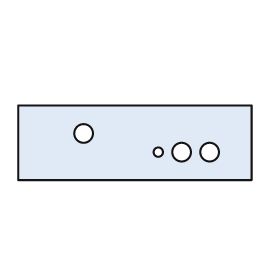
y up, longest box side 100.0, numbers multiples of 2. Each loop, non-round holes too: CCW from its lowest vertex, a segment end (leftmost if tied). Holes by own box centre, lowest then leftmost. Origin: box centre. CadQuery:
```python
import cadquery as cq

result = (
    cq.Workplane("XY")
    .moveTo(-50.0, -16.0)
    .lineTo(50.0, -16.0)
    .lineTo(50.0, 16.0)
    .lineTo(-50.0, 16.0)
    .close()
    .moveTo(10.0, -4.0)
    .circle(2.0)
    .moveTo(20.0, -4.0)
    .circle(4.0)
    .moveTo(32.0, -4.0)
    .circle(4.0)
    .moveTo(-22.0, 4.0)
    .circle(4.0)
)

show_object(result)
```